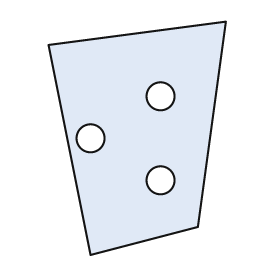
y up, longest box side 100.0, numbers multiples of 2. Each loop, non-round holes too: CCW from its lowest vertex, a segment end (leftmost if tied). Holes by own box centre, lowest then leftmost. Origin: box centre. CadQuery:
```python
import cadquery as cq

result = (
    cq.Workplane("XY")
    .moveTo(-20.0, -50.0)
    .lineTo(26.0, -38.0)
    .lineTo(38.0, 50.0)
    .lineTo(-38.0, 40.0)
    .close()
    .moveTo(10.0, -18.0)
    .circle(6.0)
    .moveTo(-20.0, 0.0)
    .circle(6.0)
    .moveTo(10.0, 18.0)
    .circle(6.0)
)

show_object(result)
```